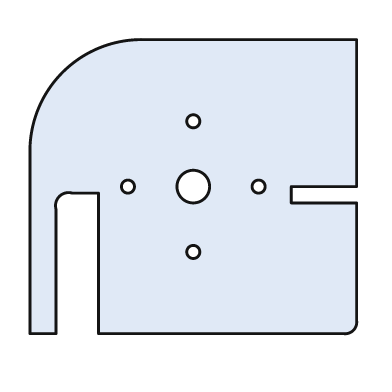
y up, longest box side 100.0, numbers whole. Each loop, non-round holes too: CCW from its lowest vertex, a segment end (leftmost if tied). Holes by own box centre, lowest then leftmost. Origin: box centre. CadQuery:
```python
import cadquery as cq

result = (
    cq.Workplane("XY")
    .moveTo(-50.0, -45.0)
    .lineTo(-42.0, -45.0)
    .lineTo(-42.0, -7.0)
    .threePointArc((-41.0, -3.0), (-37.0, -2.0))
    .lineTo(-29.0, -2.0)
    .lineTo(-29.0, -45.0)
    .lineTo(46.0, -45.0)
    .threePointArc((49.0, -44.0), (50.0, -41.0))
    .lineTo(50.0, -5.0)
    .lineTo(30.0, -5.0)
    .lineTo(30.0, 0.0)
    .lineTo(50.0, 0.0)
    .lineTo(50.0, 45.0)
    .lineTo(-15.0, 45.0)
    .threePointArc((-40.0, 35.0), (-50.0, 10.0))
    .close()
    .moveTo(0.0, -20.0)
    .circle(2.0)
    .moveTo(-20.0, 0.0)
    .circle(2.0)
    .moveTo(0.0, 0.0)
    .circle(5.0)
    .moveTo(20.0, 0.0)
    .circle(2.0)
    .moveTo(0.0, 20.0)
    .circle(2.0)
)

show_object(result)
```